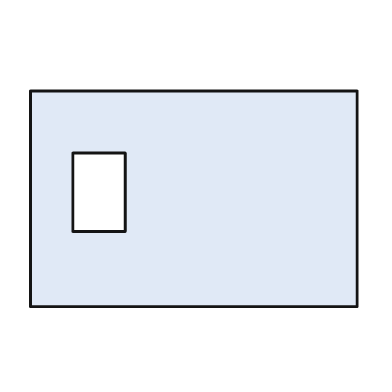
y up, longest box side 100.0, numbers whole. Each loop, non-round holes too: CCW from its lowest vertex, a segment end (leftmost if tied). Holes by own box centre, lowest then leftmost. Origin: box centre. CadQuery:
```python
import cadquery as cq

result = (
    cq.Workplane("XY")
    .moveTo(-50.0, -33.0)
    .lineTo(50.0, -33.0)
    .lineTo(50.0, 33.0)
    .lineTo(-50.0, 33.0)
    .close()
    .moveTo(-37.0, -10.0)
    .lineTo(-21.0, -10.0)
    .lineTo(-21.0, 14.0)
    .lineTo(-37.0, 14.0)
    .close()
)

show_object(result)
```